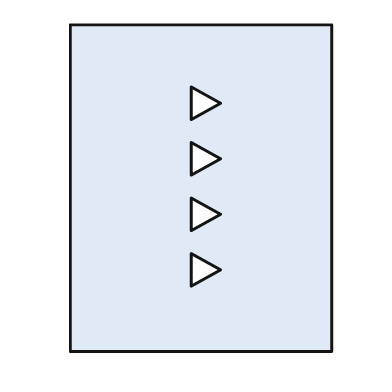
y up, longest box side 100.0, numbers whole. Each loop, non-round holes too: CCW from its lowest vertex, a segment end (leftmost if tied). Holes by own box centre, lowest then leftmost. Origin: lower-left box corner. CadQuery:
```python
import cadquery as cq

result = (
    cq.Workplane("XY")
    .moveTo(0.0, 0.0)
    .lineTo(80.0, 0.0)
    .lineTo(80.0, 100.0)
    .lineTo(0.0, 100.0)
    .close()
    .moveTo(37.0, 20.0)
    .lineTo(46.0, 25.0)
    .lineTo(37.0, 30.0)
    .close()
    .moveTo(37.0, 37.0)
    .lineTo(46.0, 42.0)
    .lineTo(37.0, 47.0)
    .close()
    .moveTo(37.0, 54.0)
    .lineTo(46.0, 59.0)
    .lineTo(37.0, 64.0)
    .close()
    .moveTo(37.0, 71.0)
    .lineTo(46.0, 76.0)
    .lineTo(37.0, 81.0)
    .close()
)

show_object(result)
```